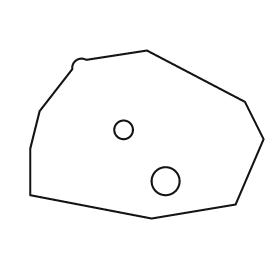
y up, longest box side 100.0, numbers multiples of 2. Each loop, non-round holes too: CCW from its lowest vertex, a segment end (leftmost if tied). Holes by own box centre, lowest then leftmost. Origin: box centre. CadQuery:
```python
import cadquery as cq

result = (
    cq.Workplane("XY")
    .moveTo(2.0, -36.0)
    .lineTo(38.0, -30.0)
    .lineTo(50.0, -2.0)
    .lineTo(42.0, 14.0)
    .lineTo(0.0, 36.0)
    .lineTo(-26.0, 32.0)
    .threePointArc((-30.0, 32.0), (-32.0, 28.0))
    .lineTo(-46.0, 10.0)
    .lineTo(-50.0, -6.0)
    .lineTo(-50.0, -26.0)
    .close()
    .moveTo(8.0, -20.0)
    .circle(6.0)
    .moveTo(-10.0, 2.0)
    .circle(4.0)
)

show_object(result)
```